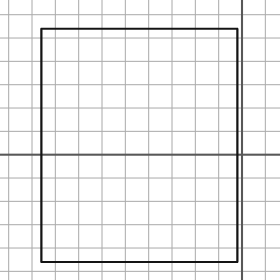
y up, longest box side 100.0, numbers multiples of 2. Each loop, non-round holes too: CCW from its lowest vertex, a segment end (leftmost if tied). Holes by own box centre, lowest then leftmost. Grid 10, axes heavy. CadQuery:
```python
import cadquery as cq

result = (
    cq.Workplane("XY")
    .moveTo(-86.0, -46.0)
    .lineTo(-2.0, -46.0)
    .lineTo(-2.0, 54.0)
    .lineTo(-86.0, 54.0)
    .close()
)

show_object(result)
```